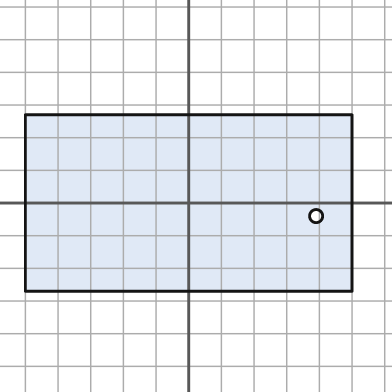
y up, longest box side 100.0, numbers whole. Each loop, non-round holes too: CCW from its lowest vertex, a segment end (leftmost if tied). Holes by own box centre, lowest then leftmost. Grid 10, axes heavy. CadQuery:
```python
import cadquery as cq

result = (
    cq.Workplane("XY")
    .moveTo(-50.0, -27.0)
    .lineTo(50.0, -27.0)
    .lineTo(50.0, 27.0)
    .lineTo(-50.0, 27.0)
    .close()
    .moveTo(39.0, -4.0)
    .circle(2.0)
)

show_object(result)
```